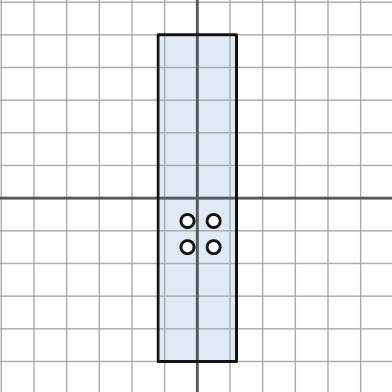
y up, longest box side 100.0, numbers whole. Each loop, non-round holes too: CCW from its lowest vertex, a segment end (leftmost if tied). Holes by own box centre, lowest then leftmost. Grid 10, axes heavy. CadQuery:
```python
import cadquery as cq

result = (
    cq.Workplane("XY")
    .moveTo(-12.0, -50.0)
    .lineTo(12.0, -50.0)
    .lineTo(12.0, 50.0)
    .lineTo(-12.0, 50.0)
    .close()
    .moveTo(-3.0, -15.0)
    .circle(2.0)
    .moveTo(5.0, -15.0)
    .circle(2.0)
    .moveTo(-3.0, -7.0)
    .circle(2.0)
    .moveTo(5.0, -7.0)
    .circle(2.0)
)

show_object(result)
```